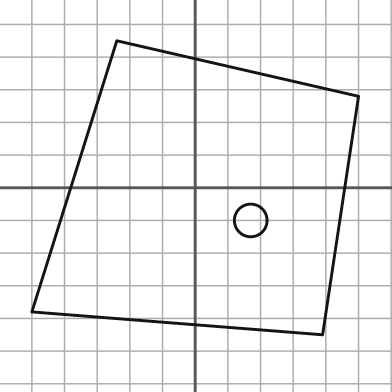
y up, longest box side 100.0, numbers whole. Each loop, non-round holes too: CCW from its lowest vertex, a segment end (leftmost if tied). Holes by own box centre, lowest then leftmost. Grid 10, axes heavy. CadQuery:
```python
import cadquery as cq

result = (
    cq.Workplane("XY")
    .moveTo(39.0, -45.0)
    .lineTo(50.0, 28.0)
    .lineTo(-24.0, 45.0)
    .lineTo(-50.0, -38.0)
    .close()
    .moveTo(17.0, -10.0)
    .circle(5.0)
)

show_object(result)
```